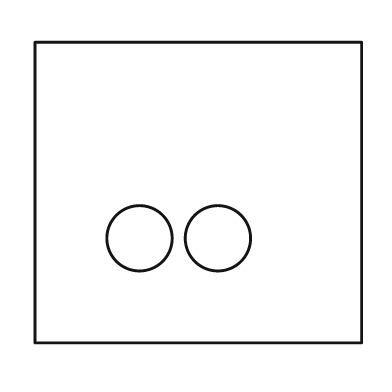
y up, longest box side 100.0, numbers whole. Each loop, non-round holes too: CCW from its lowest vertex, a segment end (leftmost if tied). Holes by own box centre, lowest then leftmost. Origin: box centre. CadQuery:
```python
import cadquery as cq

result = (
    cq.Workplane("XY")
    .moveTo(-50.0, -46.0)
    .lineTo(50.0, -46.0)
    .lineTo(50.0, 46.0)
    .lineTo(-50.0, 46.0)
    .close()
    .moveTo(-18.0, -14.0)
    .circle(10.0)
    .moveTo(6.0, -14.0)
    .circle(10.0)
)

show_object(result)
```